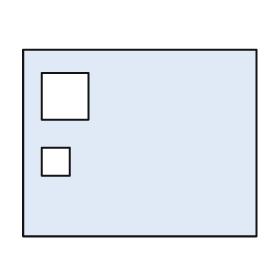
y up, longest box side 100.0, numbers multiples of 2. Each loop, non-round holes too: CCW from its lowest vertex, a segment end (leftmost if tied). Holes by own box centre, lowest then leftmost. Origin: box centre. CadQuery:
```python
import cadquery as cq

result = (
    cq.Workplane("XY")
    .moveTo(-50.0, -40.0)
    .lineTo(50.0, -40.0)
    .lineTo(50.0, 40.0)
    .lineTo(-50.0, 40.0)
    .close()
    .moveTo(-42.0, -14.0)
    .lineTo(-30.0, -14.0)
    .lineTo(-30.0, -2.0)
    .lineTo(-42.0, -2.0)
    .close()
    .moveTo(-42.0, 10.0)
    .lineTo(-22.0, 10.0)
    .lineTo(-22.0, 30.0)
    .lineTo(-42.0, 30.0)
    .close()
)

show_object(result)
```